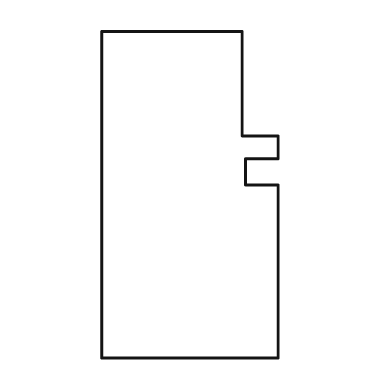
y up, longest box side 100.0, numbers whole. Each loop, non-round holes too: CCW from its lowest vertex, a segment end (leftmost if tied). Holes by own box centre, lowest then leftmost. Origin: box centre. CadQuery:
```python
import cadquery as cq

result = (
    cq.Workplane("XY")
    .moveTo(-27.0, -50.0)
    .lineTo(27.0, -50.0)
    .lineTo(27.0, 3.0)
    .lineTo(17.0, 3.0)
    .lineTo(17.0, 11.0)
    .lineTo(27.0, 11.0)
    .lineTo(27.0, 18.0)
    .lineTo(16.0, 18.0)
    .lineTo(16.0, 50.0)
    .lineTo(-27.0, 50.0)
    .close()
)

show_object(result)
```